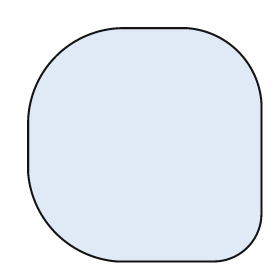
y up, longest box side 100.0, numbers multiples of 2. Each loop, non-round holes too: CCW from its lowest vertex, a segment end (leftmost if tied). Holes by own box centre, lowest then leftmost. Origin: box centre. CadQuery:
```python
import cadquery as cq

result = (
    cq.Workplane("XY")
    .moveTo(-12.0, -50.0)
    .lineTo(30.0, -50.0)
    .threePointArc((44.0, -44.0), (50.0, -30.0))
    .lineTo(50.0, 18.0)
    .threePointArc((40.0, 40.0), (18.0, 50.0))
    .lineTo(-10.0, 50.0)
    .threePointArc((-38.0, 38.0), (-50.0, 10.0))
    .lineTo(-50.0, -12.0)
    .threePointArc((-38.0, -38.0), (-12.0, -50.0))
    .close()
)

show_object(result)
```